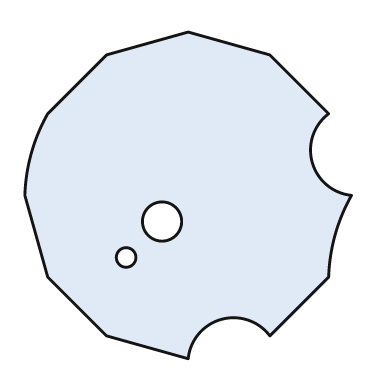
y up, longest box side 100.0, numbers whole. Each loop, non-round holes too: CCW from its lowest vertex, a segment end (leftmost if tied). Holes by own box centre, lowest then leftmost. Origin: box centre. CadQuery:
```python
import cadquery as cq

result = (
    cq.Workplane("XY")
    .moveTo(0.0, -50.0)
    .threePointArc((10.0, -38.0), (25.0, -43.0))
    .lineTo(43.0, -25.0)
    .threePointArc((45.0, -12.0), (50.0, 0.0))
    .threePointArc((38.0, 10.0), (43.0, 25.0))
    .lineTo(25.0, 43.0)
    .lineTo(0.0, 50.0)
    .lineTo(-25.0, 43.0)
    .lineTo(-43.0, 25.0)
    .threePointArc((-48.0, 13.0), (-50.0, 0.0))
    .lineTo(-43.0, -25.0)
    .lineTo(-25.0, -43.0)
    .close()
    .moveTo(-19.0, -19.0)
    .circle(3.0)
    .moveTo(-8.0, -8.0)
    .circle(6.0)
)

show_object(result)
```